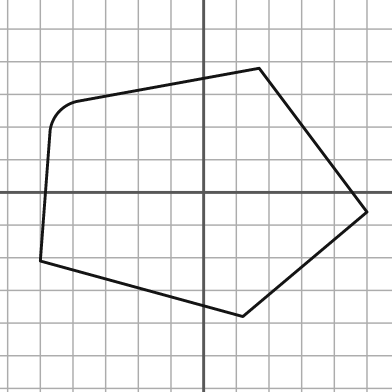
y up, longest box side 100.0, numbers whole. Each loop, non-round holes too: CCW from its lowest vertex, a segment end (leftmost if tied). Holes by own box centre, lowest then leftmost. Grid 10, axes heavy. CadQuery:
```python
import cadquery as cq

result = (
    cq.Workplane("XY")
    .moveTo(12.0, -38.0)
    .lineTo(50.0, -6.0)
    .lineTo(17.0, 38.0)
    .lineTo(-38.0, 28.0)
    .threePointArc((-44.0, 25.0), (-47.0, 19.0))
    .lineTo(-50.0, -21.0)
    .close()
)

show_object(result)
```